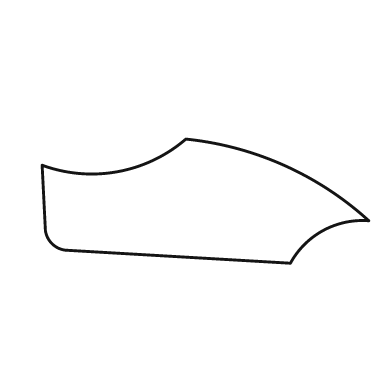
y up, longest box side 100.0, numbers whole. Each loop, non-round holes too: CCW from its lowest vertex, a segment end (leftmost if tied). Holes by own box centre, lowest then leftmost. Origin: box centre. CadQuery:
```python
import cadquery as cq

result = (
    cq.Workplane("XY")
    .moveTo(26.0, -19.0)
    .threePointArc((36.0, -9.0), (50.0, -6.0))
    .threePointArc((24.0, 11.0), (-6.0, 19.0))
    .threePointArc((-27.0, 9.0), (-50.0, 11.0))
    .lineTo(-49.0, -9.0)
    .threePointArc((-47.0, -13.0), (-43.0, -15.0))
    .close()
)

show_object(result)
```